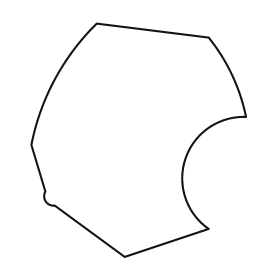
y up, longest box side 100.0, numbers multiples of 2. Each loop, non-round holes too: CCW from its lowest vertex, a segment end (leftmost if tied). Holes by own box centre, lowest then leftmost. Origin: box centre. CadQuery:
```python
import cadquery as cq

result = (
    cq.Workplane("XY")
    .moveTo(-6.0, -50.0)
    .lineTo(30.0, -38.0)
    .threePointArc((20.0, -8.0), (46.0, 10.0))
    .threePointArc((40.0, 28.0), (30.0, 44.0))
    .lineTo(-18.0, 50.0)
    .threePointArc((-36.0, 26.0), (-46.0, -2.0))
    .lineTo(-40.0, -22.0)
    .threePointArc((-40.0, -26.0), (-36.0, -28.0))
    .close()
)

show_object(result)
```